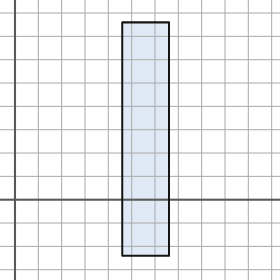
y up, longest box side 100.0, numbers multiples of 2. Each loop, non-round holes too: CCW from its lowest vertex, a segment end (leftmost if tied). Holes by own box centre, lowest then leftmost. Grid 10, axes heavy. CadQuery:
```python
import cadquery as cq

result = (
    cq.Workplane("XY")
    .moveTo(46.0, -24.0)
    .lineTo(66.0, -24.0)
    .lineTo(66.0, 76.0)
    .lineTo(46.0, 76.0)
    .close()
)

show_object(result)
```